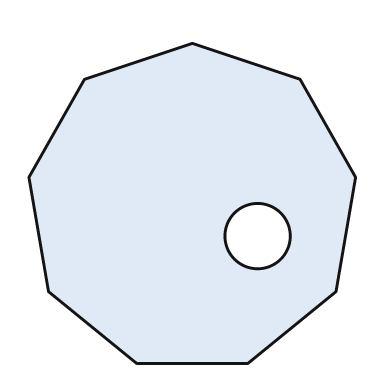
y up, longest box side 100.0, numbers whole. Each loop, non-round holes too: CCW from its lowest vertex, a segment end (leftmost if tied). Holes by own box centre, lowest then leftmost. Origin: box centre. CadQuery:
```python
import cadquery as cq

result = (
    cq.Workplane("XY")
    .moveTo(-17.0, -49.0)
    .lineTo(17.0, -49.0)
    .lineTo(44.0, -27.0)
    .lineTo(50.0, 8.0)
    .lineTo(33.0, 38.0)
    .lineTo(0.0, 49.0)
    .lineTo(-33.0, 38.0)
    .lineTo(-50.0, 8.0)
    .lineTo(-44.0, -27.0)
    .close()
    .moveTo(20.0, -10.0)
    .circle(10.0)
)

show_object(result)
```